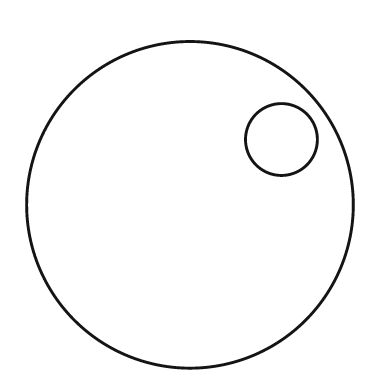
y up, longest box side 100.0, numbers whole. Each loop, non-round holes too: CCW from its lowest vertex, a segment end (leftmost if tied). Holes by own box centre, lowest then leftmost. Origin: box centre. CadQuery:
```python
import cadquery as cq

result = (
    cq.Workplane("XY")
    .moveTo(0.0, 0.0)
    .circle(50.0)
    .moveTo(28.0, 20.0)
    .circle(11.0)
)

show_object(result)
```